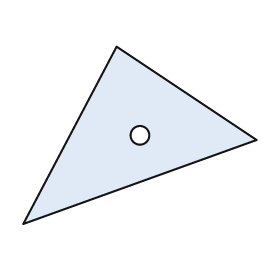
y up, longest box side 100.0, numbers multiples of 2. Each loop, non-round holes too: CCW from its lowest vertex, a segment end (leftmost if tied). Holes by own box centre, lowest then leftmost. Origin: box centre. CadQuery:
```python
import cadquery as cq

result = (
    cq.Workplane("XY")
    .moveTo(-50.0, -38.0)
    .lineTo(50.0, -2.0)
    .lineTo(-10.0, 38.0)
    .close()
    .moveTo(0.0, 0.0)
    .circle(4.0)
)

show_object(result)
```